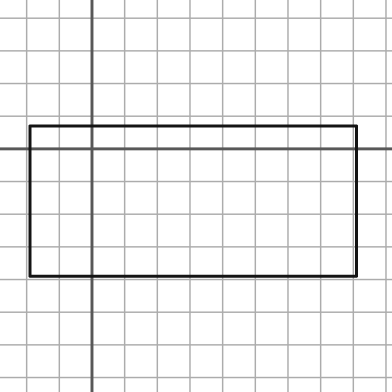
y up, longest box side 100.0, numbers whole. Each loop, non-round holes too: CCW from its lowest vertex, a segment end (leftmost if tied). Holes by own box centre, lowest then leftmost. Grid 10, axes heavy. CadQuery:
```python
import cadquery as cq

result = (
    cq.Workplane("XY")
    .moveTo(-19.0, -39.0)
    .lineTo(81.0, -39.0)
    .lineTo(81.0, 7.0)
    .lineTo(-19.0, 7.0)
    .close()
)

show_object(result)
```